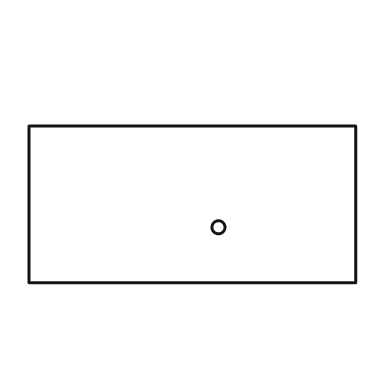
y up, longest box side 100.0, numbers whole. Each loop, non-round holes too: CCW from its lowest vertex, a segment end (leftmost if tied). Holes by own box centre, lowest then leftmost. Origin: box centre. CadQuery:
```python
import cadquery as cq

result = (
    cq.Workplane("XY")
    .moveTo(-50.0, -24.0)
    .lineTo(50.0, -24.0)
    .lineTo(50.0, 24.0)
    .lineTo(-50.0, 24.0)
    .close()
    .moveTo(8.0, -7.0)
    .circle(2.0)
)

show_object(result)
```